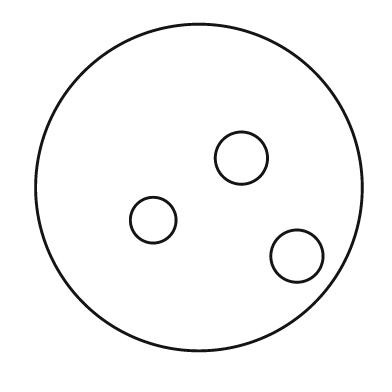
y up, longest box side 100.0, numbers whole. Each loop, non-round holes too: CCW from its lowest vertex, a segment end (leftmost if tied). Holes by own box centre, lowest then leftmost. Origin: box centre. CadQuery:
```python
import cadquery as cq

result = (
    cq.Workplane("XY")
    .moveTo(0.0, 0.0)
    .circle(50.0)
    .moveTo(30.0, -21.0)
    .circle(8.0)
    .moveTo(-14.0, -10.0)
    .circle(7.0)
    .moveTo(13.0, 9.0)
    .circle(8.0)
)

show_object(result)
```